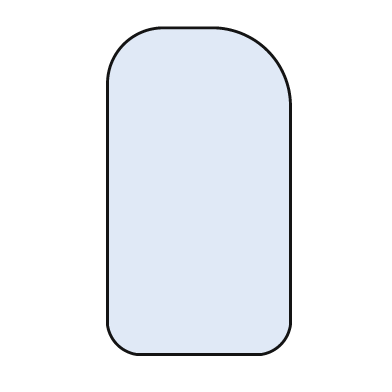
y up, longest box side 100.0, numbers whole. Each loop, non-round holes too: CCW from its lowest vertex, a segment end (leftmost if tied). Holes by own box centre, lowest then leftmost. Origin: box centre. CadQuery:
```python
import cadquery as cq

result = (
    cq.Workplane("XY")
    .moveTo(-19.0, -50.0)
    .lineTo(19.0, -50.0)
    .threePointArc((25.0, -47.0), (28.0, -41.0))
    .lineTo(28.0, 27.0)
    .threePointArc((21.0, 43.0), (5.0, 50.0))
    .lineTo(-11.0, 50.0)
    .threePointArc((-23.0, 45.0), (-28.0, 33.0))
    .lineTo(-28.0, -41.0)
    .threePointArc((-25.0, -47.0), (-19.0, -50.0))
    .close()
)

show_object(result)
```